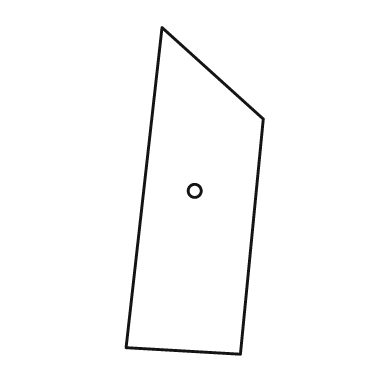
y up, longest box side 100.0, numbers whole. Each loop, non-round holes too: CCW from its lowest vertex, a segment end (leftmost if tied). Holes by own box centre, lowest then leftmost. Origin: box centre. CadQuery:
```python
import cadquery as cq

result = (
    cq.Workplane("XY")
    .moveTo(14.0, -50.0)
    .lineTo(21.0, 22.0)
    .lineTo(-10.0, 50.0)
    .lineTo(-21.0, -48.0)
    .close()
    .moveTo(0.0, 0.0)
    .circle(2.0)
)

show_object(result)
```